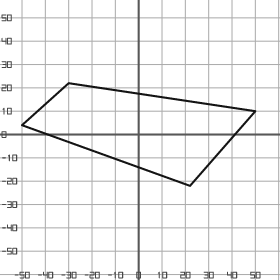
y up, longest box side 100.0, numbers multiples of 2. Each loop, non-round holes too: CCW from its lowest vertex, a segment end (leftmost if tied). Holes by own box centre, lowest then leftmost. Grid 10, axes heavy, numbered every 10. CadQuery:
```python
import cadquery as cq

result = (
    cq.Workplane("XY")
    .moveTo(22.0, -22.0)
    .lineTo(50.0, 10.0)
    .lineTo(-30.0, 22.0)
    .lineTo(-50.0, 4.0)
    .close()
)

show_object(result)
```